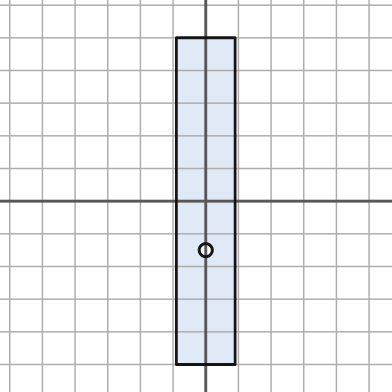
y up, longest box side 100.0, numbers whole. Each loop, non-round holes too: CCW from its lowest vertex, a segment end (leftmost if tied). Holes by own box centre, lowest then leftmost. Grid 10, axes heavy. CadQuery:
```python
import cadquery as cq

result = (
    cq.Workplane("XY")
    .moveTo(-9.0, -50.0)
    .lineTo(9.0, -50.0)
    .lineTo(9.0, 50.0)
    .lineTo(-9.0, 50.0)
    .close()
    .moveTo(0.0, -15.0)
    .circle(2.0)
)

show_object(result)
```